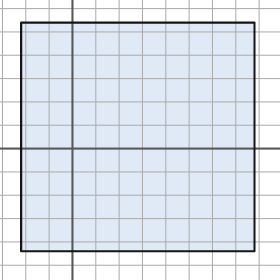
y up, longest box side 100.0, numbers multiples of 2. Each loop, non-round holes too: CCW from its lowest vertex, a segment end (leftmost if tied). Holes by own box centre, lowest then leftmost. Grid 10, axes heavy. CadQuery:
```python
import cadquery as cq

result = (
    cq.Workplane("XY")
    .moveTo(-22.0, -44.0)
    .lineTo(78.0, -44.0)
    .lineTo(78.0, 54.0)
    .lineTo(-22.0, 54.0)
    .close()
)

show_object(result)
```